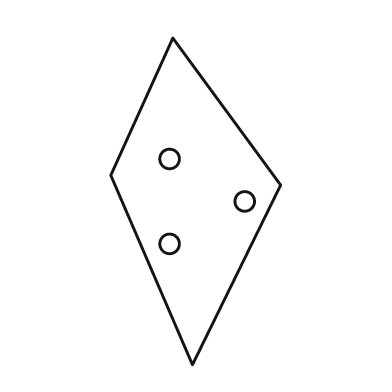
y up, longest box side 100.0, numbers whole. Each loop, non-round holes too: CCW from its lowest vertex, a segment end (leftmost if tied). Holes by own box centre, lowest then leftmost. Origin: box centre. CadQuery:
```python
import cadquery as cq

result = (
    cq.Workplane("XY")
    .moveTo(-1.0, -50.0)
    .lineTo(26.0, 5.0)
    .lineTo(-7.0, 50.0)
    .lineTo(-26.0, 8.0)
    .close()
    .moveTo(-8.0, -13.0)
    .circle(3.0)
    .moveTo(15.0, 0.0)
    .circle(3.0)
    .moveTo(-8.0, 13.0)
    .circle(3.0)
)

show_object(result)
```